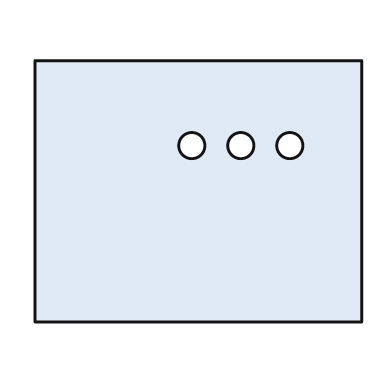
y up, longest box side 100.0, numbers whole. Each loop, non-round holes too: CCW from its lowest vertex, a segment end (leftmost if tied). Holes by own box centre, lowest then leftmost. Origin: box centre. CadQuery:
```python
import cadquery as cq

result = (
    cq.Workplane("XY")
    .moveTo(-50.0, -40.0)
    .lineTo(50.0, -40.0)
    .lineTo(50.0, 40.0)
    .lineTo(-50.0, 40.0)
    .close()
    .moveTo(-2.0, 14.0)
    .circle(4.0)
    .moveTo(13.0, 14.0)
    .circle(4.0)
    .moveTo(28.0, 14.0)
    .circle(4.0)
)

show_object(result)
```